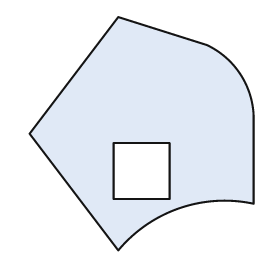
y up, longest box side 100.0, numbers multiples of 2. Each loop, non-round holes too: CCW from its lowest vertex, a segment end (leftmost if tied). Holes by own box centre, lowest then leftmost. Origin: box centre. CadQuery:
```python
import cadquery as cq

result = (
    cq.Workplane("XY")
    .moveTo(-10.0, -50.0)
    .threePointArc((16.0, -32.0), (48.0, -30.0))
    .lineTo(48.0, 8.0)
    .threePointArc((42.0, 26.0), (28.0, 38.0))
    .lineTo(-10.0, 50.0)
    .lineTo(-48.0, 0.0)
    .close()
    .moveTo(-12.0, -28.0)
    .lineTo(12.0, -28.0)
    .lineTo(12.0, -4.0)
    .lineTo(-12.0, -4.0)
    .close()
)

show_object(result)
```